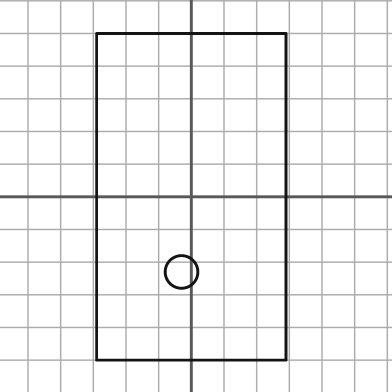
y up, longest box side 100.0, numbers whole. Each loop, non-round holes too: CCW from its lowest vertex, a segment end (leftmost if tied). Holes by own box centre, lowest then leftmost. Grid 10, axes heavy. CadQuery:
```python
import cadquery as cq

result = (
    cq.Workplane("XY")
    .moveTo(-29.0, -50.0)
    .lineTo(29.0, -50.0)
    .lineTo(29.0, 50.0)
    .lineTo(-29.0, 50.0)
    .close()
    .moveTo(-3.0, -23.0)
    .circle(5.0)
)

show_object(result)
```